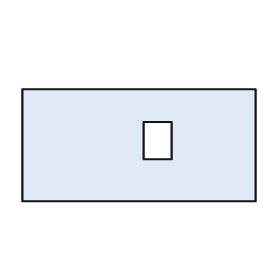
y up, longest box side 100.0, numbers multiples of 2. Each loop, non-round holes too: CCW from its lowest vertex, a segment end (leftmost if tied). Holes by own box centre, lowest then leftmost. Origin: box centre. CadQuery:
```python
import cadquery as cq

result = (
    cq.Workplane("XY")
    .moveTo(-50.0, -24.0)
    .lineTo(50.0, -24.0)
    .lineTo(50.0, 24.0)
    .lineTo(-50.0, 24.0)
    .close()
    .moveTo(2.0, -6.0)
    .lineTo(14.0, -6.0)
    .lineTo(14.0, 10.0)
    .lineTo(2.0, 10.0)
    .close()
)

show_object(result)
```